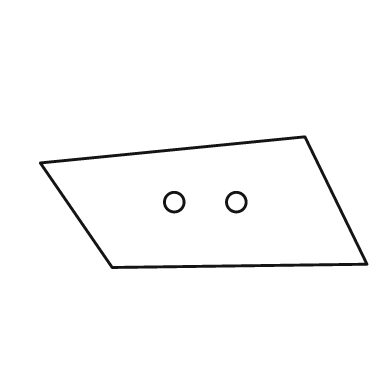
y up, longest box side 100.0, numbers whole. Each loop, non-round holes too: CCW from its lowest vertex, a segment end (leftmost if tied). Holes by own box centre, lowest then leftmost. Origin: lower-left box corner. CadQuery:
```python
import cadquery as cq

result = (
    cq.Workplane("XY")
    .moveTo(22.0, 0.0)
    .lineTo(100.0, 1.0)
    .lineTo(81.0, 40.0)
    .lineTo(0.0, 32.0)
    .close()
    .moveTo(41.0, 20.0)
    .circle(3.0)
    .moveTo(60.0, 20.0)
    .circle(3.0)
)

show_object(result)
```